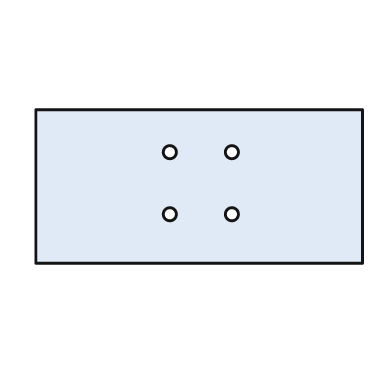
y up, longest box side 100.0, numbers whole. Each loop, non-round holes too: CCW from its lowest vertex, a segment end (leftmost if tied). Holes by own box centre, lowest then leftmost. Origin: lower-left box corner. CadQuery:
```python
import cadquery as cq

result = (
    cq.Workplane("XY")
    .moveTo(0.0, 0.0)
    .lineTo(100.0, 0.0)
    .lineTo(100.0, 47.0)
    .lineTo(0.0, 47.0)
    .close()
    .moveTo(41.0, 15.0)
    .circle(2.0)
    .moveTo(60.0, 15.0)
    .circle(2.0)
    .moveTo(41.0, 34.0)
    .circle(2.0)
    .moveTo(60.0, 34.0)
    .circle(2.0)
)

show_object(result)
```